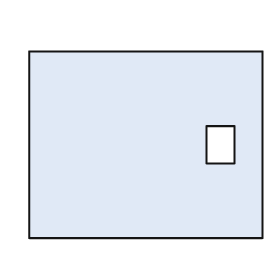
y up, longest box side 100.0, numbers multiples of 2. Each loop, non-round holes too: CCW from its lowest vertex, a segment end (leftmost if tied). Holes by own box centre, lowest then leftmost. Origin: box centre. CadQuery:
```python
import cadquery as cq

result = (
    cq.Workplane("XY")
    .moveTo(-50.0, -40.0)
    .lineTo(50.0, -40.0)
    .lineTo(50.0, 40.0)
    .lineTo(-50.0, 40.0)
    .close()
    .moveTo(26.0, -8.0)
    .lineTo(38.0, -8.0)
    .lineTo(38.0, 8.0)
    .lineTo(26.0, 8.0)
    .close()
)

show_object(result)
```